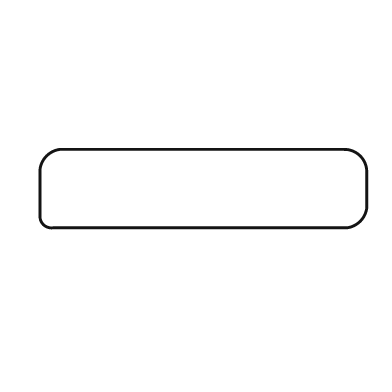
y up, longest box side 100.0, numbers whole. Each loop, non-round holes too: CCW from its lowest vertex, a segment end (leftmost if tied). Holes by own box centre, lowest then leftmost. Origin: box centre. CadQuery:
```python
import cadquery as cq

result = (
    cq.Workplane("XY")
    .moveTo(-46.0, -12.0)
    .lineTo(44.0, -12.0)
    .threePointArc((48.0, -10.0), (50.0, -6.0))
    .lineTo(50.0, 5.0)
    .threePointArc((48.0, 10.0), (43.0, 12.0))
    .lineTo(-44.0, 12.0)
    .threePointArc((-48.0, 10.0), (-50.0, 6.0))
    .lineTo(-50.0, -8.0)
    .threePointArc((-49.0, -11.0), (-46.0, -12.0))
    .close()
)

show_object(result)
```